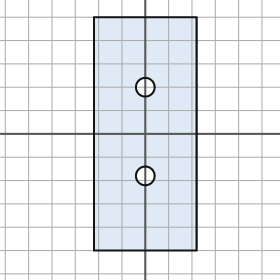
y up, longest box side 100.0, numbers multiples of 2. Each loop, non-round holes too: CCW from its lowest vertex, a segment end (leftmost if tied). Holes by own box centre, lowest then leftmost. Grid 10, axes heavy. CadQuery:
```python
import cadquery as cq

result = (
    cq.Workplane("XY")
    .moveTo(-22.0, -50.0)
    .lineTo(22.0, -50.0)
    .lineTo(22.0, 50.0)
    .lineTo(-22.0, 50.0)
    .close()
    .moveTo(0.0, -18.0)
    .circle(4.0)
    .moveTo(0.0, 20.0)
    .circle(4.0)
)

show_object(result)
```